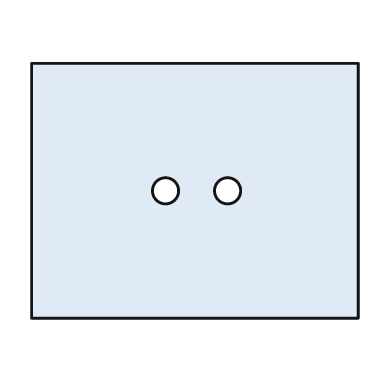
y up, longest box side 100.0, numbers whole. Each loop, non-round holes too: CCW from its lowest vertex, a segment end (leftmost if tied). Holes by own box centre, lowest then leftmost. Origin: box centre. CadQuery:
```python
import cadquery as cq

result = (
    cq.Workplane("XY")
    .moveTo(-50.0, -39.0)
    .lineTo(50.0, -39.0)
    .lineTo(50.0, 39.0)
    .lineTo(-50.0, 39.0)
    .close()
    .moveTo(-9.0, 0.0)
    .circle(4.0)
    .moveTo(10.0, 0.0)
    .circle(4.0)
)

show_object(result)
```